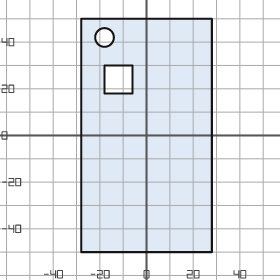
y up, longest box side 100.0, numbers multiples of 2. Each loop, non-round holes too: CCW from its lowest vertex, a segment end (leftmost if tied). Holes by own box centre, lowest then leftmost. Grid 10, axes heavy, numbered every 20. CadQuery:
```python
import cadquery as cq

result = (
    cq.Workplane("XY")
    .moveTo(-28.0, -50.0)
    .lineTo(28.0, -50.0)
    .lineTo(28.0, 50.0)
    .lineTo(-28.0, 50.0)
    .close()
    .moveTo(-18.0, 18.0)
    .lineTo(-6.0, 18.0)
    .lineTo(-6.0, 30.0)
    .lineTo(-18.0, 30.0)
    .close()
    .moveTo(-18.0, 42.0)
    .circle(4.0)
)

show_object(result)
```